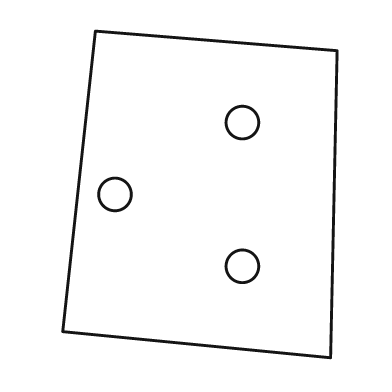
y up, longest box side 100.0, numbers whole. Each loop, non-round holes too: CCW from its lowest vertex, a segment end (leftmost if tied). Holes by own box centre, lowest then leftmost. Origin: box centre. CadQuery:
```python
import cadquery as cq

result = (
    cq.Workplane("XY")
    .moveTo(40.0, -50.0)
    .lineTo(42.0, 44.0)
    .lineTo(-32.0, 50.0)
    .lineTo(-42.0, -42.0)
    .close()
    .moveTo(13.0, -22.0)
    .circle(5.0)
    .moveTo(-26.0, 0.0)
    .circle(5.0)
    .moveTo(13.0, 22.0)
    .circle(5.0)
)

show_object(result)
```